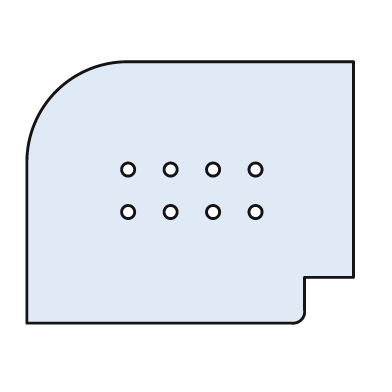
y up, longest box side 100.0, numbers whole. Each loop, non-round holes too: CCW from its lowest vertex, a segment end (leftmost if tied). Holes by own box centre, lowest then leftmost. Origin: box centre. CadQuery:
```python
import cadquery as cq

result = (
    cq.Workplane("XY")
    .moveTo(-50.0, -40.0)
    .lineTo(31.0, -40.0)
    .threePointArc((34.0, -39.0), (35.0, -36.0))
    .lineTo(35.0, -26.0)
    .lineTo(50.0, -26.0)
    .lineTo(50.0, 40.0)
    .lineTo(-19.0, 40.0)
    .threePointArc((-41.0, 31.0), (-50.0, 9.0))
    .close()
    .moveTo(-19.0, -6.0)
    .circle(2.0)
    .moveTo(-6.0, -6.0)
    .circle(2.0)
    .moveTo(7.0, -6.0)
    .circle(2.0)
    .moveTo(20.0, -6.0)
    .circle(2.0)
    .moveTo(-19.0, 7.0)
    .circle(2.0)
    .moveTo(-6.0, 7.0)
    .circle(2.0)
    .moveTo(7.0, 7.0)
    .circle(2.0)
    .moveTo(20.0, 7.0)
    .circle(2.0)
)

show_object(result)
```